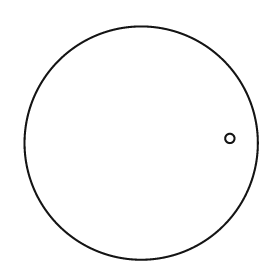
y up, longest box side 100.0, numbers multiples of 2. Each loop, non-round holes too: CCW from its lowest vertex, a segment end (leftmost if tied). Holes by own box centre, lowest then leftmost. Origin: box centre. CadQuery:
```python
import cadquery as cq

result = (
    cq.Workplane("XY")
    .moveTo(0.0, 0.0)
    .circle(50.0)
    .moveTo(38.0, 2.0)
    .circle(2.0)
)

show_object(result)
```